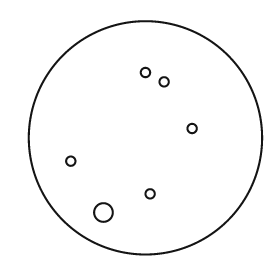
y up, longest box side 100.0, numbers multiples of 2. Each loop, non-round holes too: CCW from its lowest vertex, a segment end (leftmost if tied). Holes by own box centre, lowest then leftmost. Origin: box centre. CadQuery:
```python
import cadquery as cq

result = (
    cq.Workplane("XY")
    .moveTo(0.0, 0.0)
    .circle(50.0)
    .moveTo(-18.0, -32.0)
    .circle(4.0)
    .moveTo(2.0, -24.0)
    .circle(2.0)
    .moveTo(-32.0, -10.0)
    .circle(2.0)
    .moveTo(20.0, 4.0)
    .circle(2.0)
    .moveTo(8.0, 24.0)
    .circle(2.0)
    .moveTo(0.0, 28.0)
    .circle(2.0)
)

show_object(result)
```